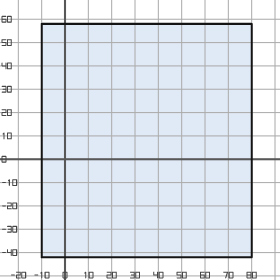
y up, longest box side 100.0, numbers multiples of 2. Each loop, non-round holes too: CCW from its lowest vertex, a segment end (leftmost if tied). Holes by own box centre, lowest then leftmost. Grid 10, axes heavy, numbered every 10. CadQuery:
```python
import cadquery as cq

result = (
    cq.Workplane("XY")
    .moveTo(-10.0, -42.0)
    .lineTo(80.0, -42.0)
    .lineTo(80.0, 58.0)
    .lineTo(-10.0, 58.0)
    .close()
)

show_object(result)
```